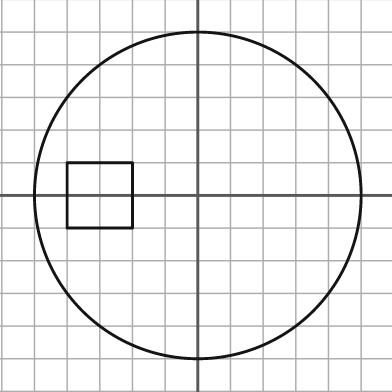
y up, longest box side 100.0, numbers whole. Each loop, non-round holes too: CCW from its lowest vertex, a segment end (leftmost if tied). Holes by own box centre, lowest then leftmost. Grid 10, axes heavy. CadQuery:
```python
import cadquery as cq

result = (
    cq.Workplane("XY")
    .moveTo(0.0, 0.0)
    .circle(50.0)
    .moveTo(-40.0, -10.0)
    .lineTo(-20.0, -10.0)
    .lineTo(-20.0, 10.0)
    .lineTo(-40.0, 10.0)
    .close()
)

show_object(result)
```